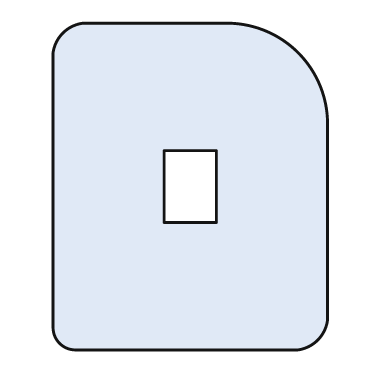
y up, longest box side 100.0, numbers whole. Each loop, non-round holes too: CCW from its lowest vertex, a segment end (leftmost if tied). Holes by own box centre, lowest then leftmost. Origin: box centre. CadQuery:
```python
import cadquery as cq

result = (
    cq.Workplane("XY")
    .moveTo(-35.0, -50.0)
    .lineTo(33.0, -50.0)
    .threePointArc((39.0, -47.0), (42.0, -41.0))
    .lineTo(42.0, 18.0)
    .threePointArc((33.0, 41.0), (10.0, 50.0))
    .lineTo(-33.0, 50.0)
    .threePointArc((-39.0, 47.0), (-42.0, 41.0))
    .lineTo(-42.0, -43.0)
    .threePointArc((-40.0, -48.0), (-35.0, -50.0))
    .close()
    .moveTo(-8.0, -11.0)
    .lineTo(8.0, -11.0)
    .lineTo(8.0, 11.0)
    .lineTo(-8.0, 11.0)
    .close()
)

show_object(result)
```